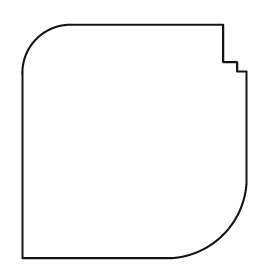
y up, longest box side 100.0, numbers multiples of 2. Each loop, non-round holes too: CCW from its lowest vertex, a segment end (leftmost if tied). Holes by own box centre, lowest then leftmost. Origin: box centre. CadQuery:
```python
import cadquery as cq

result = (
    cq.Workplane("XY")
    .moveTo(-48.0, -50.0)
    .lineTo(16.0, -50.0)
    .threePointArc((38.0, -40.0), (48.0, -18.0))
    .lineTo(48.0, 30.0)
    .lineTo(44.0, 30.0)
    .lineTo(44.0, 34.0)
    .lineTo(38.0, 34.0)
    .lineTo(38.0, 50.0)
    .lineTo(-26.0, 50.0)
    .threePointArc((-42.0, 44.0), (-48.0, 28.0))
    .close()
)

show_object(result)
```